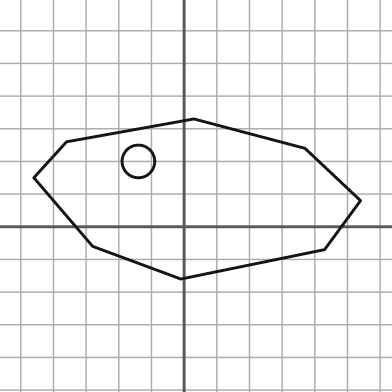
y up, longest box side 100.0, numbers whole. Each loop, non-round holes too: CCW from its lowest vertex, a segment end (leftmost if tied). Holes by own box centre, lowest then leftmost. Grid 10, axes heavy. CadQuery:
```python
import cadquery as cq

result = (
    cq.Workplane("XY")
    .moveTo(-1.0, -16.0)
    .lineTo(43.0, -7.0)
    .lineTo(54.0, 8.0)
    .lineTo(37.0, 24.0)
    .lineTo(3.0, 33.0)
    .lineTo(-36.0, 26.0)
    .lineTo(-46.0, 15.0)
    .lineTo(-28.0, -6.0)
    .close()
    .moveTo(-14.0, 20.0)
    .circle(5.0)
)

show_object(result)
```